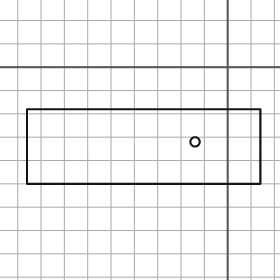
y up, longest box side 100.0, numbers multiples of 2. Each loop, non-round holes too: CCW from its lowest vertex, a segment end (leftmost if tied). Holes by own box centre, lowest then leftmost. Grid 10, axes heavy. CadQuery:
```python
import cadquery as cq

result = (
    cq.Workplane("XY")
    .moveTo(-86.0, -50.0)
    .lineTo(14.0, -50.0)
    .lineTo(14.0, -18.0)
    .lineTo(-86.0, -18.0)
    .close()
    .moveTo(-14.0, -32.0)
    .circle(2.0)
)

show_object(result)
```